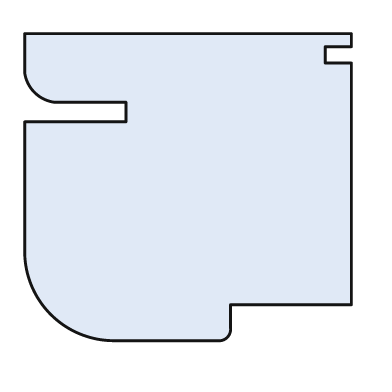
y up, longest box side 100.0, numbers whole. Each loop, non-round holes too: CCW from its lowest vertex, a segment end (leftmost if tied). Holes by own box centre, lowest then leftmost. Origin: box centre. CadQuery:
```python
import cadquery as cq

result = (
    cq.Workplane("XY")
    .moveTo(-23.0, -47.0)
    .lineTo(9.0, -47.0)
    .threePointArc((12.0, -46.0), (13.0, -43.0))
    .lineTo(13.0, -36.0)
    .lineTo(50.0, -36.0)
    .lineTo(50.0, 38.0)
    .lineTo(42.0, 38.0)
    .lineTo(42.0, 43.0)
    .lineTo(50.0, 43.0)
    .lineTo(50.0, 47.0)
    .lineTo(-50.0, 47.0)
    .lineTo(-50.0, 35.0)
    .threePointArc((-47.0, 29.0), (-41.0, 26.0))
    .lineTo(-19.0, 26.0)
    .lineTo(-19.0, 20.0)
    .lineTo(-50.0, 20.0)
    .lineTo(-50.0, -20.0)
    .threePointArc((-42.0, -39.0), (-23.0, -47.0))
    .close()
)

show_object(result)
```